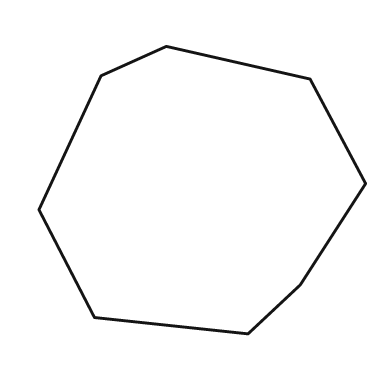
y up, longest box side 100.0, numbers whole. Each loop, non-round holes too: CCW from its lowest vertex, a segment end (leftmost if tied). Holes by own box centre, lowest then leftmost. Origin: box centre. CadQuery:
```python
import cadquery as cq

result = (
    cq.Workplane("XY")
    .moveTo(14.0, -44.0)
    .lineTo(30.0, -29.0)
    .lineTo(50.0, 2.0)
    .lineTo(33.0, 34.0)
    .lineTo(-11.0, 44.0)
    .lineTo(-31.0, 35.0)
    .lineTo(-50.0, -6.0)
    .lineTo(-33.0, -39.0)
    .close()
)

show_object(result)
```